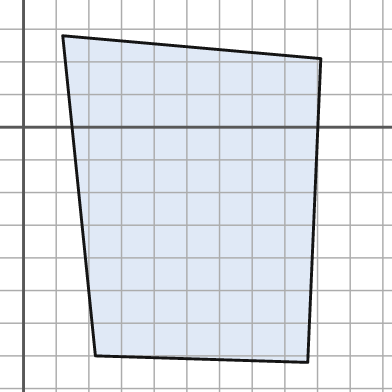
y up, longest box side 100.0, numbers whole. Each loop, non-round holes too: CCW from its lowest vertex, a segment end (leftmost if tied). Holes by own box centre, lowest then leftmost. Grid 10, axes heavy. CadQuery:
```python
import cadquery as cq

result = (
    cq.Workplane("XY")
    .moveTo(87.0, -72.0)
    .lineTo(91.0, 21.0)
    .lineTo(12.0, 28.0)
    .lineTo(22.0, -70.0)
    .close()
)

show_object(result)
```